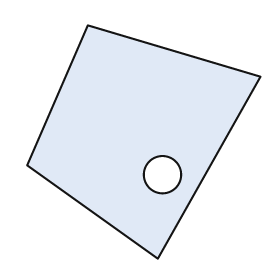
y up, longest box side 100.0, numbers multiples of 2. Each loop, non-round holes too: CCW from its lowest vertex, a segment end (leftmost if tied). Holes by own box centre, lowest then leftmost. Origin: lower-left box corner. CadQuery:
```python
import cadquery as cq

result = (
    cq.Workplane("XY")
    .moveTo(56.0, 0.0)
    .lineTo(100.0, 78.0)
    .lineTo(26.0, 100.0)
    .lineTo(0.0, 40.0)
    .close()
    .moveTo(58.0, 36.0)
    .circle(8.0)
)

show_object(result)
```